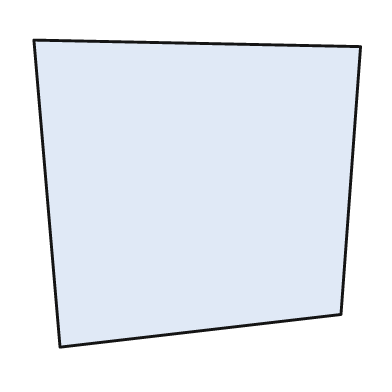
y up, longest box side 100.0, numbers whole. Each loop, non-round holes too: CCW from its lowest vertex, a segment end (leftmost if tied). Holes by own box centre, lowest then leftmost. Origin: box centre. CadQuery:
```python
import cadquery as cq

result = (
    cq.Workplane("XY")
    .moveTo(-42.0, -47.0)
    .lineTo(44.0, -37.0)
    .lineTo(50.0, 45.0)
    .lineTo(-50.0, 47.0)
    .close()
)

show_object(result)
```